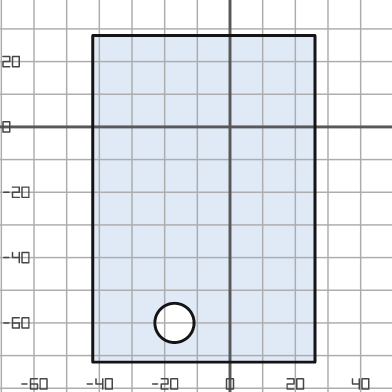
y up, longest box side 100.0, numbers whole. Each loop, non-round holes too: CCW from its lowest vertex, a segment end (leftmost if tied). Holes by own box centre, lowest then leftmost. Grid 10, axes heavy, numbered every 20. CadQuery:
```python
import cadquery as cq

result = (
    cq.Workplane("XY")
    .moveTo(-42.0, -72.0)
    .lineTo(26.0, -72.0)
    .lineTo(26.0, 28.0)
    .lineTo(-42.0, 28.0)
    .close()
    .moveTo(-17.0, -60.0)
    .circle(6.0)
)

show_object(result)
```